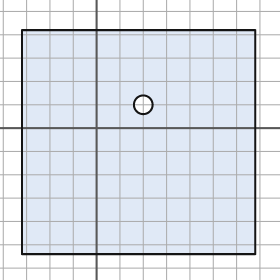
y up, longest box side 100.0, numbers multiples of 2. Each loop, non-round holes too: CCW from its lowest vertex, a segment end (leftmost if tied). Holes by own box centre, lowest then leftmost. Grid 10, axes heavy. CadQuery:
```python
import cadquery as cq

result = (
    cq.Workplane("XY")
    .moveTo(-32.0, -54.0)
    .lineTo(68.0, -54.0)
    .lineTo(68.0, 42.0)
    .lineTo(-32.0, 42.0)
    .close()
    .moveTo(20.0, 10.0)
    .circle(4.0)
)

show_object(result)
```